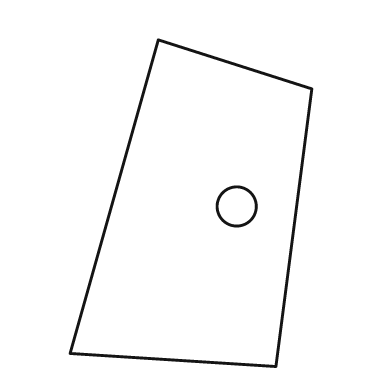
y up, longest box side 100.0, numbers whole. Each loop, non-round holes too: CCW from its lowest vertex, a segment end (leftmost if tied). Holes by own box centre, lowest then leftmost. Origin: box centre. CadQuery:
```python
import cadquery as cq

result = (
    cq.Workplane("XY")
    .moveTo(26.0, -50.0)
    .lineTo(37.0, 35.0)
    .lineTo(-10.0, 50.0)
    .lineTo(-37.0, -46.0)
    .close()
    .moveTo(14.0, -1.0)
    .circle(6.0)
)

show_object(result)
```